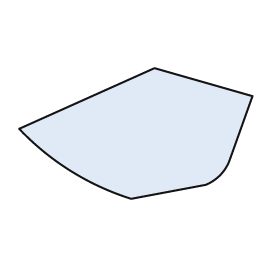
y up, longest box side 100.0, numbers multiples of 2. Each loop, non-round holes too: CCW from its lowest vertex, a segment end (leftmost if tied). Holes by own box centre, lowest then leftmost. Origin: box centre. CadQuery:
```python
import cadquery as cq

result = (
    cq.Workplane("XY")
    .moveTo(-2.0, -28.0)
    .lineTo(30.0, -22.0)
    .threePointArc((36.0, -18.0), (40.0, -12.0))
    .lineTo(50.0, 16.0)
    .lineTo(8.0, 28.0)
    .lineTo(-50.0, 2.0)
    .threePointArc((-28.0, -16.0), (-2.0, -28.0))
    .close()
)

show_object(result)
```